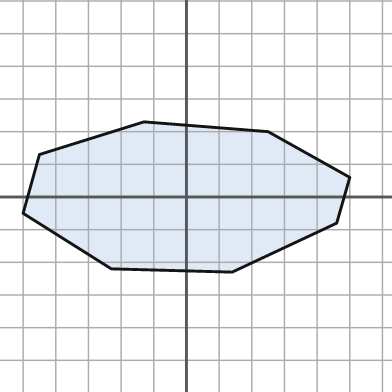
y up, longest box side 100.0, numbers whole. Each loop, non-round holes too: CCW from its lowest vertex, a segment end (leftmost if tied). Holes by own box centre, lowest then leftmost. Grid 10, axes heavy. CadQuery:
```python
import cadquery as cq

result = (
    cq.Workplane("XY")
    .moveTo(14.0, -23.0)
    .lineTo(46.0, -8.0)
    .lineTo(50.0, 6.0)
    .lineTo(25.0, 20.0)
    .lineTo(-13.0, 23.0)
    .lineTo(-45.0, 13.0)
    .lineTo(-50.0, -5.0)
    .lineTo(-23.0, -22.0)
    .close()
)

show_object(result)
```